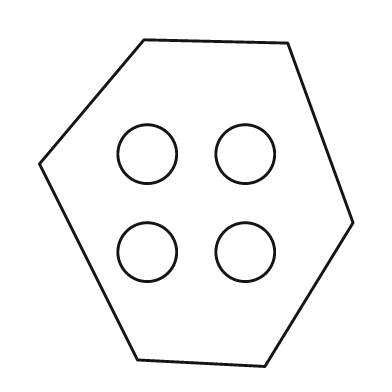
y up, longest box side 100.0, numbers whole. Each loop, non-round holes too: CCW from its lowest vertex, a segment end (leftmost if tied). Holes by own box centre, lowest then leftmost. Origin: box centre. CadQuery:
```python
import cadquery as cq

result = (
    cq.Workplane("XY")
    .moveTo(21.0, -50.0)
    .lineTo(48.0, -6.0)
    .lineTo(28.0, 49.0)
    .lineTo(-16.0, 50.0)
    .lineTo(-48.0, 12.0)
    .lineTo(-18.0, -48.0)
    .close()
    .moveTo(-15.0, -15.0)
    .circle(9.0)
    .moveTo(15.0, -15.0)
    .circle(9.0)
    .moveTo(-15.0, 15.0)
    .circle(9.0)
    .moveTo(15.0, 15.0)
    .circle(9.0)
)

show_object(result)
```